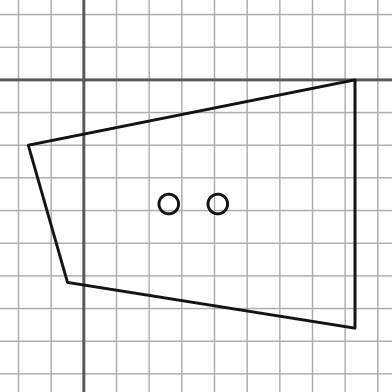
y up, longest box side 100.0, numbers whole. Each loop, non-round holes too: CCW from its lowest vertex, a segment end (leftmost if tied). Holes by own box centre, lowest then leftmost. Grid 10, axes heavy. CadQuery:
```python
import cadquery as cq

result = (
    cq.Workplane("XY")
    .moveTo(83.0, -76.0)
    .lineTo(83.0, 0.0)
    .lineTo(-17.0, -20.0)
    .lineTo(-5.0, -62.0)
    .close()
    .moveTo(26.0, -38.0)
    .circle(3.0)
    .moveTo(41.0, -38.0)
    .circle(3.0)
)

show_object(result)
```